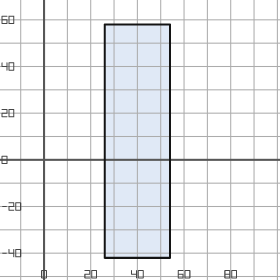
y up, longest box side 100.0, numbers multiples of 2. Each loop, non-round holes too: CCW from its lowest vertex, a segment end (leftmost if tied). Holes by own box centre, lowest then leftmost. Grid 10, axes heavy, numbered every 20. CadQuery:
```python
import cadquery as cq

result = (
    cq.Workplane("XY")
    .moveTo(26.0, -42.0)
    .lineTo(54.0, -42.0)
    .lineTo(54.0, 58.0)
    .lineTo(26.0, 58.0)
    .close()
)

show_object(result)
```